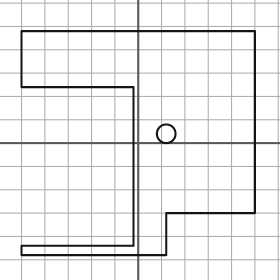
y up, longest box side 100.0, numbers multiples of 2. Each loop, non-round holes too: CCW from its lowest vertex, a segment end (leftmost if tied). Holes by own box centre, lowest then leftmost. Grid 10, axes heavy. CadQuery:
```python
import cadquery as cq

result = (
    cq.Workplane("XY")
    .moveTo(-50.0, -48.0)
    .lineTo(12.0, -48.0)
    .lineTo(12.0, -30.0)
    .lineTo(50.0, -30.0)
    .lineTo(50.0, 48.0)
    .lineTo(-50.0, 48.0)
    .lineTo(-50.0, 24.0)
    .lineTo(-2.0, 24.0)
    .lineTo(-2.0, -44.0)
    .lineTo(-50.0, -44.0)
    .close()
    .moveTo(12.0, 4.0)
    .circle(4.0)
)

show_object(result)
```